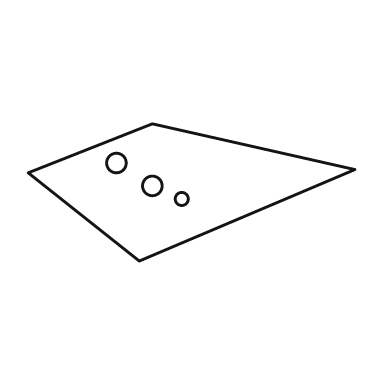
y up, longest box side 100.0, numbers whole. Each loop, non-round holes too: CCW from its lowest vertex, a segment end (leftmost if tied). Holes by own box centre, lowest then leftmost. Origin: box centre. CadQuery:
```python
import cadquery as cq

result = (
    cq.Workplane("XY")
    .moveTo(-16.0, -21.0)
    .lineTo(50.0, 7.0)
    .lineTo(-12.0, 21.0)
    .lineTo(-50.0, 6.0)
    .close()
    .moveTo(-3.0, -2.0)
    .circle(2.0)
    .moveTo(-12.0, 2.0)
    .circle(3.0)
    .moveTo(-23.0, 9.0)
    .circle(3.0)
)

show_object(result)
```